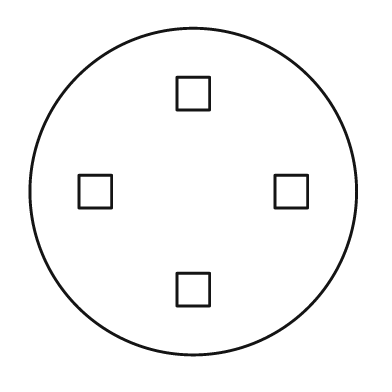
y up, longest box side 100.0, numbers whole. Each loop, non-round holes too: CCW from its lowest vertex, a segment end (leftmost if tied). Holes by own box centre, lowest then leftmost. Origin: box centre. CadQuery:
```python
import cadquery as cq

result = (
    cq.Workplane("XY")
    .moveTo(0.0, 0.0)
    .circle(50.0)
    .moveTo(-5.0, -35.0)
    .lineTo(5.0, -35.0)
    .lineTo(5.0, -25.0)
    .lineTo(-5.0, -25.0)
    .close()
    .moveTo(-35.0, -5.0)
    .lineTo(-25.0, -5.0)
    .lineTo(-25.0, 5.0)
    .lineTo(-35.0, 5.0)
    .close()
    .moveTo(25.0, -5.0)
    .lineTo(35.0, -5.0)
    .lineTo(35.0, 5.0)
    .lineTo(25.0, 5.0)
    .close()
    .moveTo(-5.0, 25.0)
    .lineTo(5.0, 25.0)
    .lineTo(5.0, 35.0)
    .lineTo(-5.0, 35.0)
    .close()
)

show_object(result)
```